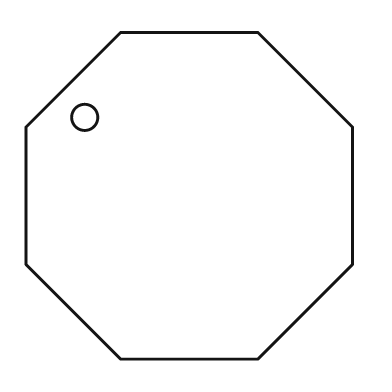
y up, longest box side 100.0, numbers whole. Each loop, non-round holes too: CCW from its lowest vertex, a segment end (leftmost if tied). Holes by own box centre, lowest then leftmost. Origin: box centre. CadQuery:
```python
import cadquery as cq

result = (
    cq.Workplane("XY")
    .moveTo(-21.0, -50.0)
    .lineTo(21.0, -50.0)
    .lineTo(50.0, -21.0)
    .lineTo(50.0, 21.0)
    .lineTo(21.0, 50.0)
    .lineTo(-21.0, 50.0)
    .lineTo(-50.0, 21.0)
    .lineTo(-50.0, -21.0)
    .close()
    .moveTo(-32.0, 24.0)
    .circle(4.0)
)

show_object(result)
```